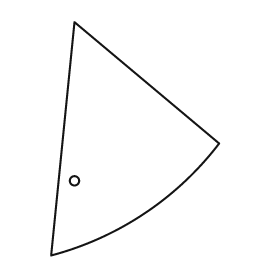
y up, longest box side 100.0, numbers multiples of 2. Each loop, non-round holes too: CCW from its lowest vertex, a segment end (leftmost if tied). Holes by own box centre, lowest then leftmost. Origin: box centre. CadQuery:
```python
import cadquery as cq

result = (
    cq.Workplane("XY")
    .moveTo(-36.0, -50.0)
    .threePointArc((4.0, -32.0), (36.0, -2.0))
    .lineTo(-26.0, 50.0)
    .close()
    .moveTo(-26.0, -18.0)
    .circle(2.0)
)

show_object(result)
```